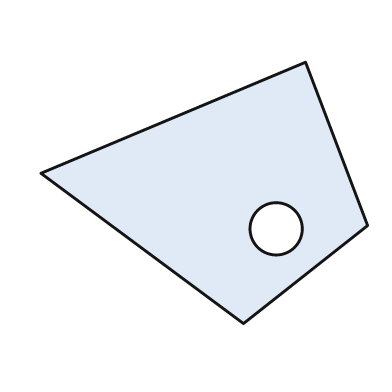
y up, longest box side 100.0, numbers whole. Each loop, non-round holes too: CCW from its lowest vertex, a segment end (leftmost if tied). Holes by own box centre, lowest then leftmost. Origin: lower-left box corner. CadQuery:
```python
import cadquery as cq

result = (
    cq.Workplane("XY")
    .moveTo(62.0, 0.0)
    .lineTo(100.0, 30.0)
    .lineTo(81.0, 80.0)
    .lineTo(0.0, 46.0)
    .close()
    .moveTo(72.0, 29.0)
    .circle(8.0)
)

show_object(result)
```